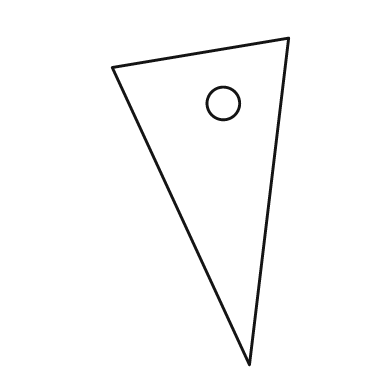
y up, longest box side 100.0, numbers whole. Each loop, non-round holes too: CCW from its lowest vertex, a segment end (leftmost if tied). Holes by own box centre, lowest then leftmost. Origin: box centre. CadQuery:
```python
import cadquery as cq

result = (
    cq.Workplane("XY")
    .moveTo(15.0, -50.0)
    .lineTo(27.0, 50.0)
    .lineTo(-27.0, 41.0)
    .close()
    .moveTo(7.0, 30.0)
    .circle(5.0)
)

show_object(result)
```